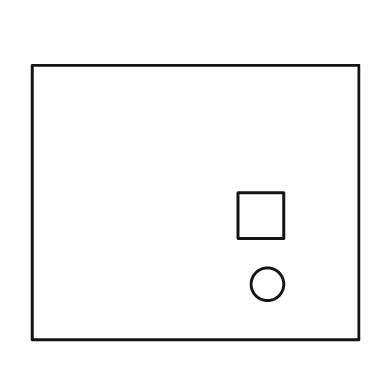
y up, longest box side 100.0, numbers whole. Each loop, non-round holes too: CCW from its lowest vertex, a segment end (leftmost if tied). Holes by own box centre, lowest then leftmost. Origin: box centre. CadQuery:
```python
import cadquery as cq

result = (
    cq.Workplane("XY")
    .moveTo(-50.0, -42.0)
    .lineTo(50.0, -42.0)
    .lineTo(50.0, 42.0)
    .lineTo(-50.0, 42.0)
    .close()
    .moveTo(22.0, -25.0)
    .circle(5.0)
    .moveTo(13.0, -11.0)
    .lineTo(27.0, -11.0)
    .lineTo(27.0, 3.0)
    .lineTo(13.0, 3.0)
    .close()
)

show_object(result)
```